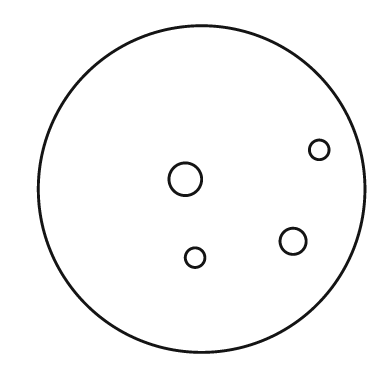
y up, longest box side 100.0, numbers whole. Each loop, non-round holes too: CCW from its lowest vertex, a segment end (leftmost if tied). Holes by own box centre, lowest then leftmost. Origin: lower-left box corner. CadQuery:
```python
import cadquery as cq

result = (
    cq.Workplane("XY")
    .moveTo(50.0, 50.0)
    .circle(50.0)
    .moveTo(48.0, 29.0)
    .circle(3.0)
    .moveTo(78.0, 34.0)
    .circle(4.0)
    .moveTo(45.0, 53.0)
    .circle(5.0)
    .moveTo(86.0, 62.0)
    .circle(3.0)
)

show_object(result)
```